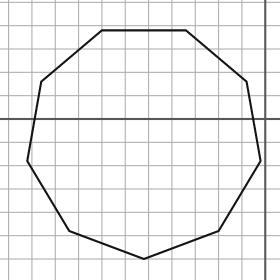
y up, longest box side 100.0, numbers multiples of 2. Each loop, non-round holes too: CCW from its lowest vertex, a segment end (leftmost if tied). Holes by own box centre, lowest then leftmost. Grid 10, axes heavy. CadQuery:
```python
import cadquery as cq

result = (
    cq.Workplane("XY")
    .moveTo(-52.0, -60.0)
    .lineTo(-20.0, -48.0)
    .lineTo(-2.0, -18.0)
    .lineTo(-8.0, 16.0)
    .lineTo(-34.0, 38.0)
    .lineTo(-70.0, 38.0)
    .lineTo(-96.0, 16.0)
    .lineTo(-102.0, -18.0)
    .lineTo(-84.0, -48.0)
    .close()
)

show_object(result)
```